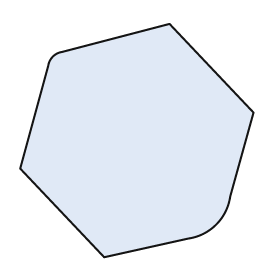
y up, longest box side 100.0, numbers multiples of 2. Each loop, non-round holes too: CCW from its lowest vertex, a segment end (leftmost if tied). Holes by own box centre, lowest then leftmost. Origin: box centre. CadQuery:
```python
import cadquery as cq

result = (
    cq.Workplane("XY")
    .moveTo(-14.0, -50.0)
    .lineTo(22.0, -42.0)
    .threePointArc((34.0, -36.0), (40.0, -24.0))
    .lineTo(50.0, 12.0)
    .lineTo(14.0, 50.0)
    .lineTo(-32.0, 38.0)
    .threePointArc((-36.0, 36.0), (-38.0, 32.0))
    .lineTo(-50.0, -12.0)
    .close()
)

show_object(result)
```